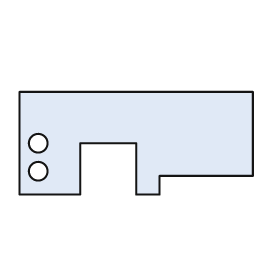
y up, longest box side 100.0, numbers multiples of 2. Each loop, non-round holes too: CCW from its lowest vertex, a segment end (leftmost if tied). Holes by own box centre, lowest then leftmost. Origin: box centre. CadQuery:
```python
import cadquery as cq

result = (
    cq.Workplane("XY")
    .moveTo(-50.0, -22.0)
    .lineTo(-24.0, -22.0)
    .lineTo(-24.0, 0.0)
    .lineTo(0.0, 0.0)
    .lineTo(0.0, -22.0)
    .lineTo(10.0, -22.0)
    .lineTo(10.0, -14.0)
    .lineTo(50.0, -14.0)
    .lineTo(50.0, 22.0)
    .lineTo(-50.0, 22.0)
    .close()
    .moveTo(-42.0, -12.0)
    .circle(4.0)
    .moveTo(-42.0, 0.0)
    .circle(4.0)
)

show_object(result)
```